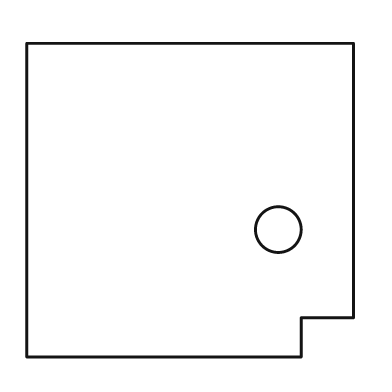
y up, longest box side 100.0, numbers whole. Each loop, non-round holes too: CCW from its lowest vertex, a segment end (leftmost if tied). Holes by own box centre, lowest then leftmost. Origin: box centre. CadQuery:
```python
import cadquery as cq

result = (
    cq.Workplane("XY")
    .moveTo(-50.0, -48.0)
    .lineTo(34.0, -48.0)
    .lineTo(34.0, -36.0)
    .lineTo(50.0, -36.0)
    .lineTo(50.0, 48.0)
    .lineTo(-50.0, 48.0)
    .close()
    .moveTo(27.0, -9.0)
    .circle(7.0)
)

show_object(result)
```